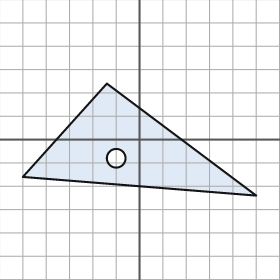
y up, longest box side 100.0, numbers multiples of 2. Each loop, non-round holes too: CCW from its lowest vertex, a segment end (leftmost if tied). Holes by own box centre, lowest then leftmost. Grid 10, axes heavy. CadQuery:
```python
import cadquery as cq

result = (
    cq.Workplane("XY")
    .moveTo(50.0, -24.0)
    .lineTo(-14.0, 24.0)
    .lineTo(-50.0, -16.0)
    .close()
    .moveTo(-10.0, -8.0)
    .circle(4.0)
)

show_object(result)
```